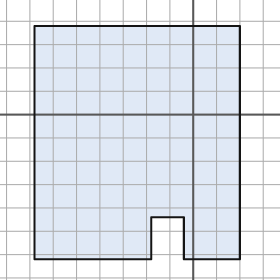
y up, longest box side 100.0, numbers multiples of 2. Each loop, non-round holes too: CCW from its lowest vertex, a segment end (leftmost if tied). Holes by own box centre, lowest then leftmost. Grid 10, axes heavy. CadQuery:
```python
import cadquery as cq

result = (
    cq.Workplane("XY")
    .moveTo(-68.0, -62.0)
    .lineTo(-18.0, -62.0)
    .lineTo(-18.0, -44.0)
    .lineTo(-4.0, -44.0)
    .lineTo(-4.0, -62.0)
    .lineTo(20.0, -62.0)
    .lineTo(20.0, 38.0)
    .lineTo(-68.0, 38.0)
    .close()
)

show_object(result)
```